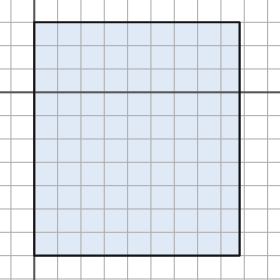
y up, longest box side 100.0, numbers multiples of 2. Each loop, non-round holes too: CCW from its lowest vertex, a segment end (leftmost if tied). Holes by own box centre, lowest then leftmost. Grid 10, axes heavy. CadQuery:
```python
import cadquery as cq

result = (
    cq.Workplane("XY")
    .moveTo(0.0, -70.0)
    .lineTo(88.0, -70.0)
    .lineTo(88.0, 30.0)
    .lineTo(0.0, 30.0)
    .close()
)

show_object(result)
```